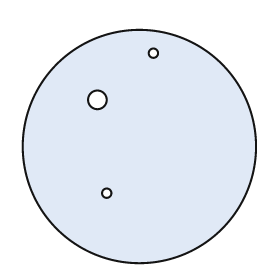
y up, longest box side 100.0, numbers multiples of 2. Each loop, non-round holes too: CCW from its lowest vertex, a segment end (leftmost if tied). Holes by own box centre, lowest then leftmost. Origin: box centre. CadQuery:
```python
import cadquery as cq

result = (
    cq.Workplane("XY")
    .moveTo(0.0, 0.0)
    .circle(50.0)
    .moveTo(-14.0, -20.0)
    .circle(2.0)
    .moveTo(-18.0, 20.0)
    .circle(4.0)
    .moveTo(6.0, 40.0)
    .circle(2.0)
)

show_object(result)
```